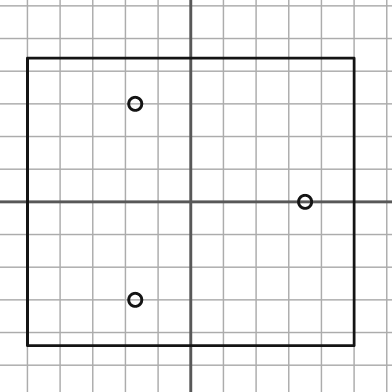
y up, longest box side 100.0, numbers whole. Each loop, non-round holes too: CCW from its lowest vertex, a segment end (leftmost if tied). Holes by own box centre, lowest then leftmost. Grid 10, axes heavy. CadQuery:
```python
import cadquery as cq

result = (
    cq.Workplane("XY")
    .moveTo(-50.0, -44.0)
    .lineTo(50.0, -44.0)
    .lineTo(50.0, 44.0)
    .lineTo(-50.0, 44.0)
    .close()
    .moveTo(-17.0, -30.0)
    .circle(2.0)
    .moveTo(35.0, 0.0)
    .circle(2.0)
    .moveTo(-17.0, 30.0)
    .circle(2.0)
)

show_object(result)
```